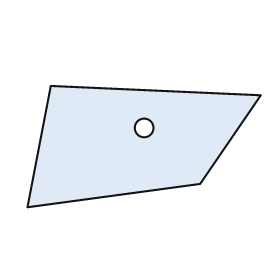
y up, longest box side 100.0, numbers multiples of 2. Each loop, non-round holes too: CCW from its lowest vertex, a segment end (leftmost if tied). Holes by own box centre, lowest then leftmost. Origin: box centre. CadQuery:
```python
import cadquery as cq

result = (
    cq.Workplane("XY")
    .moveTo(-50.0, -26.0)
    .lineTo(24.0, -16.0)
    .lineTo(50.0, 22.0)
    .lineTo(-40.0, 26.0)
    .close()
    .moveTo(0.0, 8.0)
    .circle(4.0)
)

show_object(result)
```